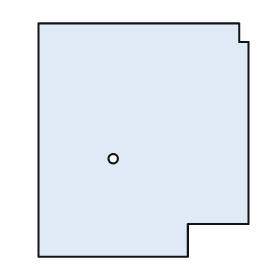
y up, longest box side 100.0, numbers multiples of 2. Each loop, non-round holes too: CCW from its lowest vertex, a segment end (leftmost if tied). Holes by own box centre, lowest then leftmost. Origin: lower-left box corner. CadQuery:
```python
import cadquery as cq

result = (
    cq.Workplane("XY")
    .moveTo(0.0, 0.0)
    .lineTo(64.0, 0.0)
    .lineTo(64.0, 14.0)
    .lineTo(90.0, 14.0)
    .lineTo(90.0, 92.0)
    .lineTo(86.0, 92.0)
    .lineTo(86.0, 100.0)
    .lineTo(0.0, 100.0)
    .close()
    .moveTo(32.0, 42.0)
    .circle(2.0)
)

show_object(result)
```